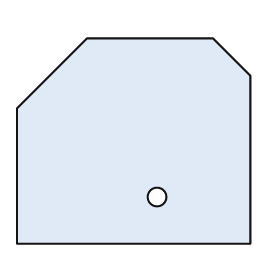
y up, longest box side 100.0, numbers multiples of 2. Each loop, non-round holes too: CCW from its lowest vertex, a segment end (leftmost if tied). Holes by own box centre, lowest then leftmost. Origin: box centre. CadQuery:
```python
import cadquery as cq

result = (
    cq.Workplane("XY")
    .moveTo(-50.0, -44.0)
    .lineTo(50.0, -44.0)
    .lineTo(50.0, 28.0)
    .lineTo(34.0, 44.0)
    .lineTo(-20.0, 44.0)
    .lineTo(-50.0, 14.0)
    .close()
    .moveTo(10.0, -24.0)
    .circle(4.0)
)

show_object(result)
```